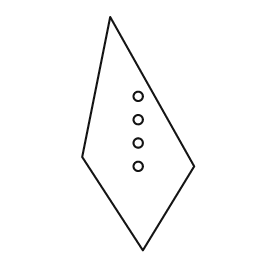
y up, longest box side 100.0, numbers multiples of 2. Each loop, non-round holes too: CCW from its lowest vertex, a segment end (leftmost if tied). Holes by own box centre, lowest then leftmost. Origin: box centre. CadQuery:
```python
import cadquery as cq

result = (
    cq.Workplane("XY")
    .moveTo(2.0, -50.0)
    .lineTo(24.0, -14.0)
    .lineTo(-12.0, 50.0)
    .lineTo(-24.0, -10.0)
    .close()
    .moveTo(0.0, -14.0)
    .circle(2.0)
    .moveTo(0.0, -4.0)
    .circle(2.0)
    .moveTo(0.0, 6.0)
    .circle(2.0)
    .moveTo(0.0, 16.0)
    .circle(2.0)
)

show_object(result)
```